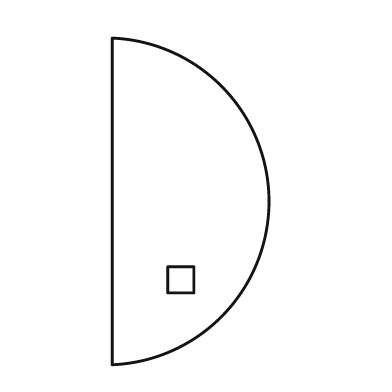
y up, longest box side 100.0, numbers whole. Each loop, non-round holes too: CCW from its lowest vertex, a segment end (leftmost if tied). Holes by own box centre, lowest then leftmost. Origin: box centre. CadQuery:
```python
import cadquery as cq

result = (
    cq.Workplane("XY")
    .moveTo(-24.0, -50.0)
    .threePointArc((24.0, 0.0), (-24.0, 50.0))
    .close()
    .moveTo(-7.0, -28.0)
    .lineTo(1.0, -28.0)
    .lineTo(1.0, -20.0)
    .lineTo(-7.0, -20.0)
    .close()
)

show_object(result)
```